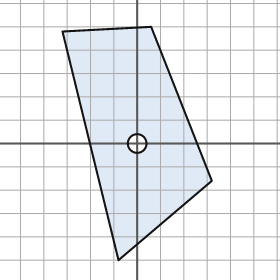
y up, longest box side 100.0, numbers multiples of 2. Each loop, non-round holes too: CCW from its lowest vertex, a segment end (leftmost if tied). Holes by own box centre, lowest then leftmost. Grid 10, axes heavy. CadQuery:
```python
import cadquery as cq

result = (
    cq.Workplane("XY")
    .moveTo(-8.0, -50.0)
    .lineTo(32.0, -16.0)
    .lineTo(6.0, 50.0)
    .lineTo(-32.0, 48.0)
    .close()
    .moveTo(0.0, 0.0)
    .circle(4.0)
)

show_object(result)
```